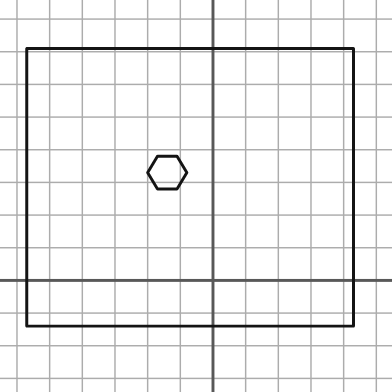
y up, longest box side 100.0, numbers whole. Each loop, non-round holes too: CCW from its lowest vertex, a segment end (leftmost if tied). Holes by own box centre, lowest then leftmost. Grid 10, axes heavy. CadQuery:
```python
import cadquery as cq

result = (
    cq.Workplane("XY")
    .moveTo(-57.0, -14.0)
    .lineTo(43.0, -14.0)
    .lineTo(43.0, 71.0)
    .lineTo(-57.0, 71.0)
    .close()
    .moveTo(-17.0, 28.0)
    .lineTo(-11.0, 28.0)
    .lineTo(-8.0, 33.0)
    .lineTo(-11.0, 38.0)
    .lineTo(-17.0, 38.0)
    .lineTo(-20.0, 33.0)
    .close()
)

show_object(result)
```